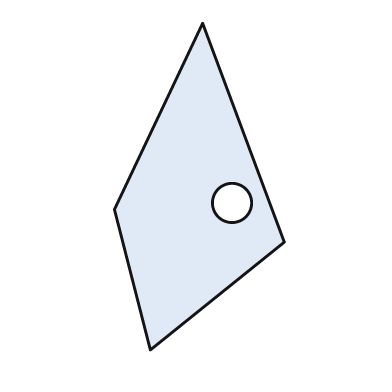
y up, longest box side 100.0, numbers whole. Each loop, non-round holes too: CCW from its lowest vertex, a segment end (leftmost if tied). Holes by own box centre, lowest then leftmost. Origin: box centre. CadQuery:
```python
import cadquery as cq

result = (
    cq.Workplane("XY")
    .moveTo(-15.0, -50.0)
    .lineTo(26.0, -17.0)
    .lineTo(1.0, 50.0)
    .lineTo(-26.0, -7.0)
    .close()
    .moveTo(10.0, -5.0)
    .circle(6.0)
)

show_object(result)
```